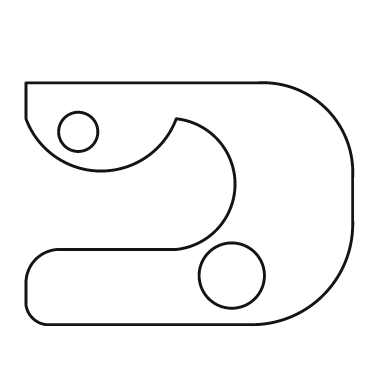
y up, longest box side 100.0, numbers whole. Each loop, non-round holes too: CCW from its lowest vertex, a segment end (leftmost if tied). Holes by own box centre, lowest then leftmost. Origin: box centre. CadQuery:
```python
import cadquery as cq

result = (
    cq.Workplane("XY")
    .moveTo(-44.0, -37.0)
    .lineTo(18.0, -37.0)
    .threePointArc((41.0, -28.0), (50.0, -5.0))
    .lineTo(50.0, 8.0)
    .threePointArc((42.0, 29.0), (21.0, 37.0))
    .lineTo(-50.0, 37.0)
    .lineTo(-50.0, 26.0)
    .threePointArc((-27.0, 10.0), (-4.0, 26.0))
    .threePointArc((14.0, 6.0), (-4.0, -14.0))
    .lineTo(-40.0, -14.0)
    .threePointArc((-47.0, -17.0), (-50.0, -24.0))
    .lineTo(-50.0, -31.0)
    .threePointArc((-48.0, -35.0), (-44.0, -37.0))
    .close()
    .moveTo(13.0, -22.0)
    .circle(10.0)
    .moveTo(-34.0, 22.0)
    .circle(6.0)
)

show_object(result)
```